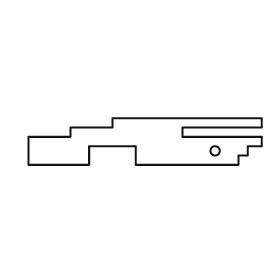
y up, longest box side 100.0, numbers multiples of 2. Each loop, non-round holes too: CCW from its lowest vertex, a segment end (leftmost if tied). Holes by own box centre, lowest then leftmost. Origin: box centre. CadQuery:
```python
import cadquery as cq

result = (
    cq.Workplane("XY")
    .moveTo(-50.0, -10.0)
    .lineTo(-24.0, -10.0)
    .lineTo(-24.0, -2.0)
    .lineTo(-4.0, -2.0)
    .lineTo(-4.0, -10.0)
    .lineTo(40.0, -10.0)
    .lineTo(40.0, -6.0)
    .lineTo(44.0, -6.0)
    .lineTo(44.0, -2.0)
    .lineTo(50.0, -2.0)
    .lineTo(50.0, 2.0)
    .lineTo(16.0, 2.0)
    .lineTo(16.0, 6.0)
    .lineTo(50.0, 6.0)
    .lineTo(50.0, 10.0)
    .lineTo(-14.0, 10.0)
    .lineTo(-14.0, 6.0)
    .lineTo(-32.0, 6.0)
    .lineTo(-32.0, 2.0)
    .lineTo(-50.0, 2.0)
    .close()
    .moveTo(30.0, -4.0)
    .circle(2.0)
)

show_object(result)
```